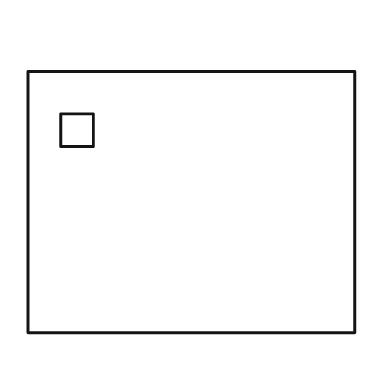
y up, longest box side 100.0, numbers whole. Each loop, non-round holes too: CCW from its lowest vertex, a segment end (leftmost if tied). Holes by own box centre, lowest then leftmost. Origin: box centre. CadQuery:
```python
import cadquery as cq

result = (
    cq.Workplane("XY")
    .moveTo(-50.0, -40.0)
    .lineTo(50.0, -40.0)
    .lineTo(50.0, 40.0)
    .lineTo(-50.0, 40.0)
    .close()
    .moveTo(-40.0, 17.0)
    .lineTo(-30.0, 17.0)
    .lineTo(-30.0, 27.0)
    .lineTo(-40.0, 27.0)
    .close()
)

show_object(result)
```